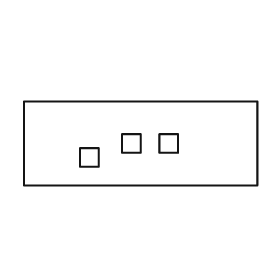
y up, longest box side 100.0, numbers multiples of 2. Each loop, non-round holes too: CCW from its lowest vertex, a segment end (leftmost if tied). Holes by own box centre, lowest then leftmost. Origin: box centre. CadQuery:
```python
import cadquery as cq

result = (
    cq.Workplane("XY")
    .moveTo(-50.0, -18.0)
    .lineTo(50.0, -18.0)
    .lineTo(50.0, 18.0)
    .lineTo(-50.0, 18.0)
    .close()
    .moveTo(-26.0, -10.0)
    .lineTo(-18.0, -10.0)
    .lineTo(-18.0, -2.0)
    .lineTo(-26.0, -2.0)
    .close()
    .moveTo(-8.0, -4.0)
    .lineTo(0.0, -4.0)
    .lineTo(0.0, 4.0)
    .lineTo(-8.0, 4.0)
    .close()
    .moveTo(8.0, -4.0)
    .lineTo(16.0, -4.0)
    .lineTo(16.0, 4.0)
    .lineTo(8.0, 4.0)
    .close()
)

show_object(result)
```